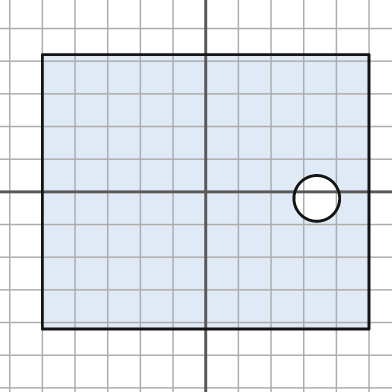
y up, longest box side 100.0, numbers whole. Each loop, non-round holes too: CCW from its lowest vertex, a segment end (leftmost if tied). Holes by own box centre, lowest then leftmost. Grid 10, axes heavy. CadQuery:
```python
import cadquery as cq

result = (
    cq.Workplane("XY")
    .moveTo(-50.0, -42.0)
    .lineTo(50.0, -42.0)
    .lineTo(50.0, 42.0)
    .lineTo(-50.0, 42.0)
    .close()
    .moveTo(34.0, -2.0)
    .circle(7.0)
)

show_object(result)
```